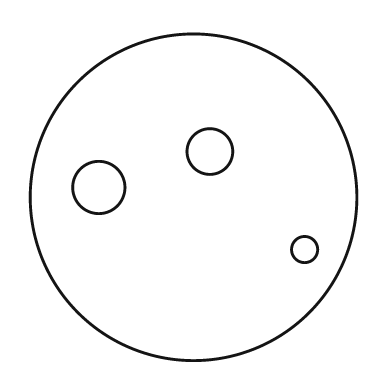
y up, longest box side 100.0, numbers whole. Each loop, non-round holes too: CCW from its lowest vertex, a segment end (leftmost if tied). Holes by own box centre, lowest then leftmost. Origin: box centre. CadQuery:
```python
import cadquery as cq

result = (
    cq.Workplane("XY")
    .moveTo(0.0, 0.0)
    .circle(50.0)
    .moveTo(34.0, -16.0)
    .circle(4.0)
    .moveTo(-29.0, 3.0)
    .circle(8.0)
    .moveTo(5.0, 14.0)
    .circle(7.0)
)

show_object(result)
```